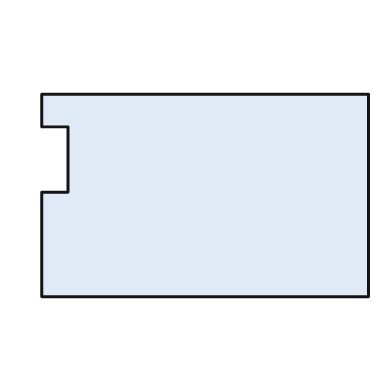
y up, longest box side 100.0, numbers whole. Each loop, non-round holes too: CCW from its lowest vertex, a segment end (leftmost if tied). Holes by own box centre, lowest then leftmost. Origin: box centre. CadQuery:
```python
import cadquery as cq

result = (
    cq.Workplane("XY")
    .moveTo(-50.0, -31.0)
    .lineTo(50.0, -31.0)
    .lineTo(50.0, 31.0)
    .lineTo(-50.0, 31.0)
    .lineTo(-50.0, 21.0)
    .lineTo(-42.0, 21.0)
    .lineTo(-42.0, 1.0)
    .lineTo(-50.0, 1.0)
    .close()
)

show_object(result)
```